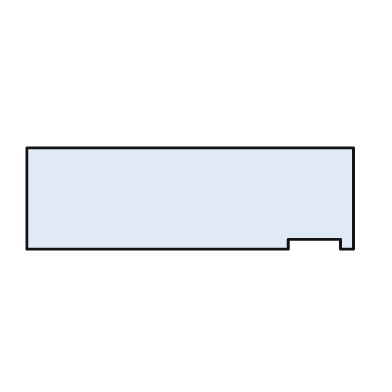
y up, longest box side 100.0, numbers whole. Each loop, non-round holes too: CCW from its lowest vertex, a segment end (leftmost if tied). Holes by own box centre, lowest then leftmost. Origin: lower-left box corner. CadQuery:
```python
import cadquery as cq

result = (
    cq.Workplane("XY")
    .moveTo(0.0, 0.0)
    .lineTo(80.0, 0.0)
    .lineTo(80.0, 3.0)
    .lineTo(96.0, 3.0)
    .lineTo(96.0, 0.0)
    .lineTo(100.0, 0.0)
    .lineTo(100.0, 31.0)
    .lineTo(0.0, 31.0)
    .close()
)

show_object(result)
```